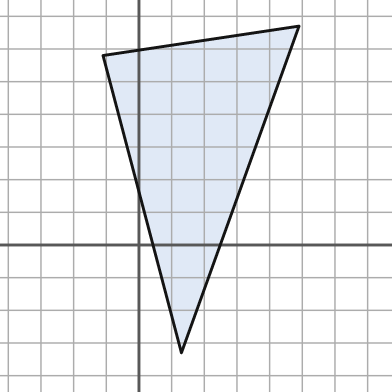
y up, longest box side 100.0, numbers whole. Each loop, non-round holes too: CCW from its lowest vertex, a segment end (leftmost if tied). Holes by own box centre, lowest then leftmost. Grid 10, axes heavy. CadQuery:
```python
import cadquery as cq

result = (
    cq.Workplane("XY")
    .moveTo(13.0, -33.0)
    .lineTo(49.0, 67.0)
    .lineTo(-11.0, 58.0)
    .close()
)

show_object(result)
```